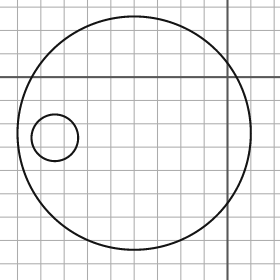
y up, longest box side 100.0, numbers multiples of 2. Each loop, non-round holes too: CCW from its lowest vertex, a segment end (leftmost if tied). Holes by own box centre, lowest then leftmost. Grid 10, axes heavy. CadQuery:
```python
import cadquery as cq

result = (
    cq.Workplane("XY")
    .moveTo(-40.0, -24.0)
    .circle(50.0)
    .moveTo(-74.0, -26.0)
    .circle(10.0)
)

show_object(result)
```